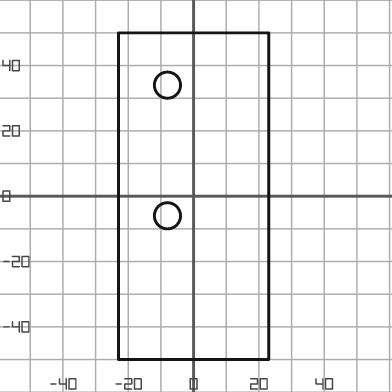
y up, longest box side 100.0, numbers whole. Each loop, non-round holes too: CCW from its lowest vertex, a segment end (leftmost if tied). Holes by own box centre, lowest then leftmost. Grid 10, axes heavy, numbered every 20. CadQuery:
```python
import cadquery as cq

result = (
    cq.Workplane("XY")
    .moveTo(-23.0, -50.0)
    .lineTo(23.0, -50.0)
    .lineTo(23.0, 50.0)
    .lineTo(-23.0, 50.0)
    .close()
    .moveTo(-8.0, -6.0)
    .circle(4.0)
    .moveTo(-8.0, 34.0)
    .circle(4.0)
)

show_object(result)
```